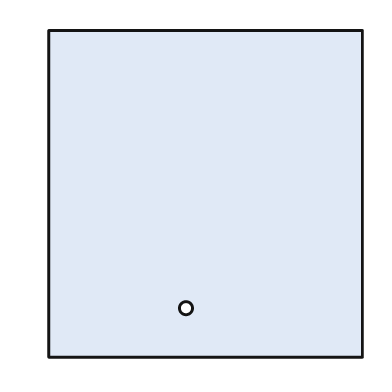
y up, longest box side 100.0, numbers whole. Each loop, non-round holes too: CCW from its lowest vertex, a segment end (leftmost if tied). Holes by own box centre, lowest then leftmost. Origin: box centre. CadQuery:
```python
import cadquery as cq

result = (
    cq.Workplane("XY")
    .moveTo(-48.0, -50.0)
    .lineTo(48.0, -50.0)
    .lineTo(48.0, 50.0)
    .lineTo(-48.0, 50.0)
    .close()
    .moveTo(-6.0, -35.0)
    .circle(2.0)
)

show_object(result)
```